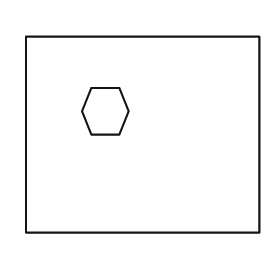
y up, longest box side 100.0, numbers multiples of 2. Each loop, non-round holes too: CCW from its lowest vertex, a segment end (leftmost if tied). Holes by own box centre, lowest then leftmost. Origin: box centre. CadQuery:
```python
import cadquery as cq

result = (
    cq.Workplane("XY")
    .moveTo(-50.0, -42.0)
    .lineTo(50.0, -42.0)
    .lineTo(50.0, 42.0)
    .lineTo(-50.0, 42.0)
    .close()
    .moveTo(-22.0, 0.0)
    .lineTo(-10.0, 0.0)
    .lineTo(-6.0, 10.0)
    .lineTo(-10.0, 20.0)
    .lineTo(-22.0, 20.0)
    .lineTo(-26.0, 10.0)
    .close()
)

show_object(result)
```